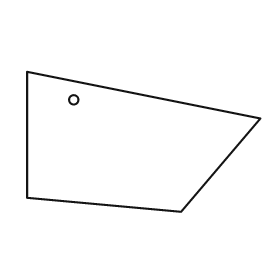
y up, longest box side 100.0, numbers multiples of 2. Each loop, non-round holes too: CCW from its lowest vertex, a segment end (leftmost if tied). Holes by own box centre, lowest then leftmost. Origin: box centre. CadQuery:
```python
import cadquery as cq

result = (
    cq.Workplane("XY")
    .moveTo(16.0, -30.0)
    .lineTo(50.0, 10.0)
    .lineTo(-50.0, 30.0)
    .lineTo(-50.0, -24.0)
    .close()
    .moveTo(-30.0, 18.0)
    .circle(2.0)
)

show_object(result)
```